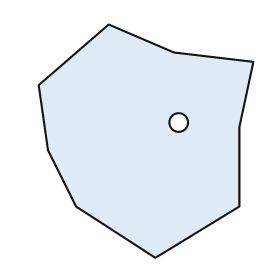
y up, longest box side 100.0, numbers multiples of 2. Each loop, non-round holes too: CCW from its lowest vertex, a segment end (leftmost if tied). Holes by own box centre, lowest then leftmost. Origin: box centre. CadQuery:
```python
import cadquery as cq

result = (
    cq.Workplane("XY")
    .moveTo(4.0, -50.0)
    .lineTo(40.0, -28.0)
    .lineTo(40.0, 6.0)
    .lineTo(46.0, 34.0)
    .lineTo(12.0, 38.0)
    .lineTo(-16.0, 50.0)
    .lineTo(-46.0, 24.0)
    .lineTo(-42.0, -4.0)
    .lineTo(-30.0, -28.0)
    .close()
    .moveTo(14.0, 8.0)
    .circle(4.0)
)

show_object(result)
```